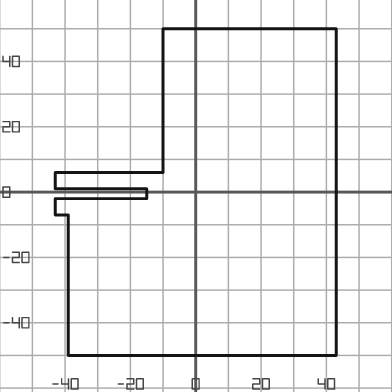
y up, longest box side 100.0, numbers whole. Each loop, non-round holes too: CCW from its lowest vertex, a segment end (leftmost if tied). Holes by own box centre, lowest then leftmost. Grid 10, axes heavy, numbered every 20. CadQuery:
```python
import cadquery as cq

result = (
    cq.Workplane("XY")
    .moveTo(-39.0, -50.0)
    .lineTo(43.0, -50.0)
    .lineTo(43.0, 50.0)
    .lineTo(-10.0, 50.0)
    .lineTo(-10.0, 6.0)
    .lineTo(-43.0, 6.0)
    .lineTo(-43.0, 1.0)
    .lineTo(-15.0, 1.0)
    .lineTo(-15.0, -2.0)
    .lineTo(-43.0, -2.0)
    .lineTo(-43.0, -7.0)
    .lineTo(-39.0, -7.0)
    .close()
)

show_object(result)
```